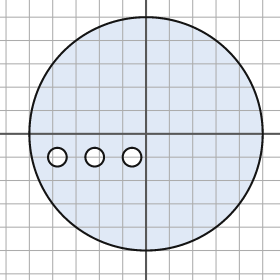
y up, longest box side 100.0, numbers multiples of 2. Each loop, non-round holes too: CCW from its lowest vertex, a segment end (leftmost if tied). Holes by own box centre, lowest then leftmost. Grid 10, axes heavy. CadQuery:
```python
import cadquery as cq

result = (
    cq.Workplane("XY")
    .moveTo(0.0, 0.0)
    .circle(50.0)
    .moveTo(-38.0, -10.0)
    .circle(4.0)
    .moveTo(-22.0, -10.0)
    .circle(4.0)
    .moveTo(-6.0, -10.0)
    .circle(4.0)
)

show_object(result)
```